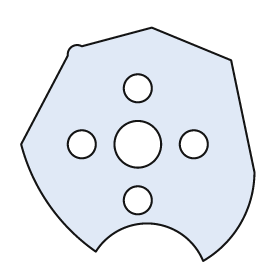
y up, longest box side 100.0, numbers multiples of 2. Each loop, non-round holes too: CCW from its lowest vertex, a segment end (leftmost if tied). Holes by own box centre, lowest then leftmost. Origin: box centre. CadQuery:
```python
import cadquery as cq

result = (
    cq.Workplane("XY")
    .moveTo(28.0, -50.0)
    .threePointArc((44.0, -34.0), (50.0, -12.0))
    .lineTo(40.0, 36.0)
    .lineTo(6.0, 50.0)
    .lineTo(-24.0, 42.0)
    .threePointArc((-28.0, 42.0), (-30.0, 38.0))
    .lineTo(-50.0, 0.0)
    .threePointArc((-38.0, -26.0), (-18.0, -46.0))
    .threePointArc((6.0, -34.0), (28.0, -50.0))
    .close()
    .moveTo(0.0, -24.0)
    .circle(6.0)
    .moveTo(-24.0, 0.0)
    .circle(6.0)
    .moveTo(0.0, 0.0)
    .circle(10.0)
    .moveTo(24.0, 0.0)
    .circle(6.0)
    .moveTo(0.0, 24.0)
    .circle(6.0)
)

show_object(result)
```